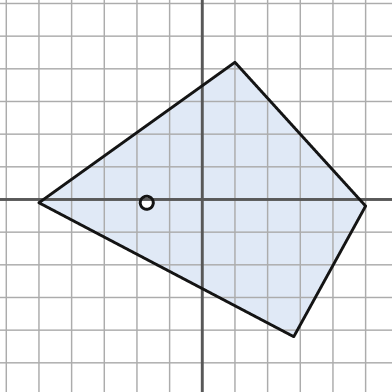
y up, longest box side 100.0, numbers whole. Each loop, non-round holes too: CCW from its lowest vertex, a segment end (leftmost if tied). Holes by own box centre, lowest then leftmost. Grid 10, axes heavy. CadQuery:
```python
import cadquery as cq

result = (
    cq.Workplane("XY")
    .moveTo(28.0, -42.0)
    .lineTo(50.0, -2.0)
    .lineTo(10.0, 42.0)
    .lineTo(-50.0, -1.0)
    .close()
    .moveTo(-17.0, -1.0)
    .circle(2.0)
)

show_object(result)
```